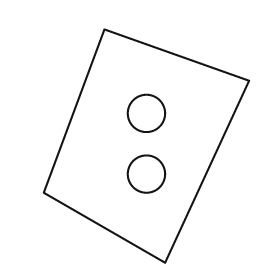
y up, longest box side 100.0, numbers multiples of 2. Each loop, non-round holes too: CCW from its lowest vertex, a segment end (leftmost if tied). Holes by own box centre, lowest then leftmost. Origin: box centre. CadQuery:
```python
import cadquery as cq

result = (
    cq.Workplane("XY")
    .moveTo(8.0, -50.0)
    .lineTo(44.0, 28.0)
    .lineTo(-18.0, 50.0)
    .lineTo(-44.0, -20.0)
    .close()
    .moveTo(0.0, -12.0)
    .circle(8.0)
    .moveTo(0.0, 14.0)
    .circle(8.0)
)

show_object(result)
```